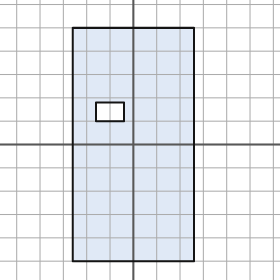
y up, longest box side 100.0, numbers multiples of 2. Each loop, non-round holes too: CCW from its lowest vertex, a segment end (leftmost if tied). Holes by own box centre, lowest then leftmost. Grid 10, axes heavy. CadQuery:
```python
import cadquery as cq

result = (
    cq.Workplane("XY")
    .moveTo(-26.0, -50.0)
    .lineTo(26.0, -50.0)
    .lineTo(26.0, 50.0)
    .lineTo(-26.0, 50.0)
    .close()
    .moveTo(-16.0, 10.0)
    .lineTo(-4.0, 10.0)
    .lineTo(-4.0, 18.0)
    .lineTo(-16.0, 18.0)
    .close()
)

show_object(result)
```